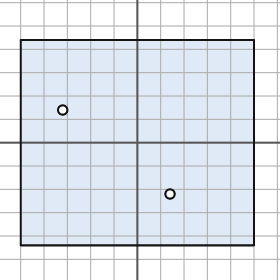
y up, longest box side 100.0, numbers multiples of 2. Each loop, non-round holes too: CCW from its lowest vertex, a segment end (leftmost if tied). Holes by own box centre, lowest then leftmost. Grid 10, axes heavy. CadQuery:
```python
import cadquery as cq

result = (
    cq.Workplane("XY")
    .moveTo(-50.0, -44.0)
    .lineTo(50.0, -44.0)
    .lineTo(50.0, 44.0)
    .lineTo(-50.0, 44.0)
    .close()
    .moveTo(14.0, -22.0)
    .circle(2.0)
    .moveTo(-32.0, 14.0)
    .circle(2.0)
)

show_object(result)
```